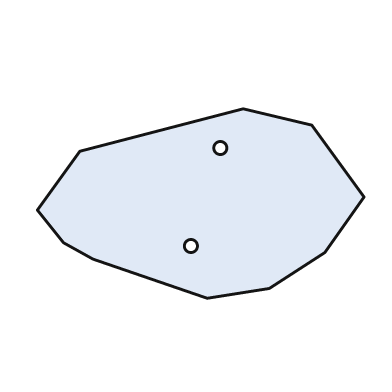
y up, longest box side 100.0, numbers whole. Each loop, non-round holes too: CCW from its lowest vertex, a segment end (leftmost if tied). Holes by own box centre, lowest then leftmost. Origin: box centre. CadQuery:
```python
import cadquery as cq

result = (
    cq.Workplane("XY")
    .moveTo(2.0, -29.0)
    .lineTo(21.0, -26.0)
    .lineTo(38.0, -15.0)
    .lineTo(50.0, 2.0)
    .lineTo(34.0, 24.0)
    .lineTo(13.0, 29.0)
    .lineTo(-37.0, 16.0)
    .lineTo(-50.0, -2.0)
    .lineTo(-42.0, -12.0)
    .lineTo(-33.0, -17.0)
    .close()
    .moveTo(-3.0, -13.0)
    .circle(2.0)
    .moveTo(6.0, 17.0)
    .circle(2.0)
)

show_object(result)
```